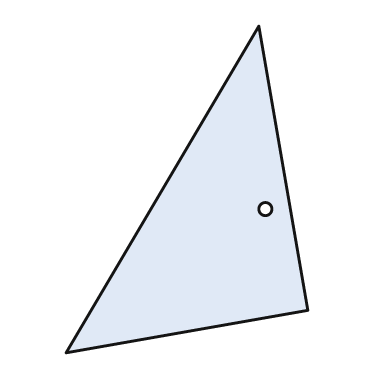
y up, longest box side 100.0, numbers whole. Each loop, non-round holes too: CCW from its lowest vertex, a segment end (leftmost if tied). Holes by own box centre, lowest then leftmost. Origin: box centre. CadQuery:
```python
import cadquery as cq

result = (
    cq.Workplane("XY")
    .moveTo(-37.0, -50.0)
    .lineTo(37.0, -37.0)
    .lineTo(22.0, 50.0)
    .close()
    .moveTo(24.0, -6.0)
    .circle(2.0)
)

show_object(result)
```